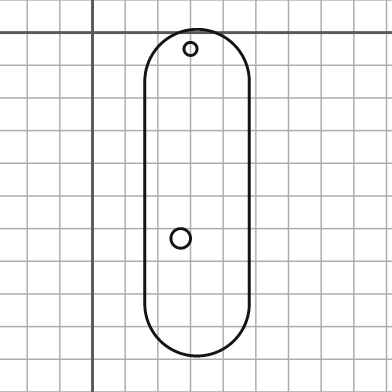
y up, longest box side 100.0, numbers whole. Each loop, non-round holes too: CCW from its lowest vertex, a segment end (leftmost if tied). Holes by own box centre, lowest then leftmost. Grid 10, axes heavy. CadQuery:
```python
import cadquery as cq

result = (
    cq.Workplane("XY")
    .moveTo(16.0, -83.0)
    .threePointArc((32.0, -99.0), (48.0, -83.0))
    .lineTo(48.0, -15.0)
    .threePointArc((32.0, 1.0), (16.0, -15.0))
    .close()
    .moveTo(27.0, -63.0)
    .circle(3.0)
    .moveTo(30.0, -5.0)
    .circle(2.0)
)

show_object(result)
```